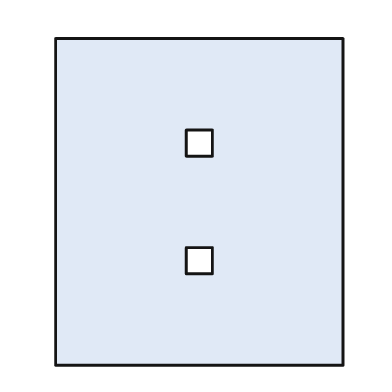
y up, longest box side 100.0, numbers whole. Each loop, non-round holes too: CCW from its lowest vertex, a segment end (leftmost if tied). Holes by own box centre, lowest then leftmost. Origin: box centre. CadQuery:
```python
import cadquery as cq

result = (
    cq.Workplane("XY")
    .moveTo(-44.0, -50.0)
    .lineTo(44.0, -50.0)
    .lineTo(44.0, 50.0)
    .lineTo(-44.0, 50.0)
    .close()
    .moveTo(-4.0, -22.0)
    .lineTo(4.0, -22.0)
    .lineTo(4.0, -14.0)
    .lineTo(-4.0, -14.0)
    .close()
    .moveTo(-4.0, 14.0)
    .lineTo(4.0, 14.0)
    .lineTo(4.0, 22.0)
    .lineTo(-4.0, 22.0)
    .close()
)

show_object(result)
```